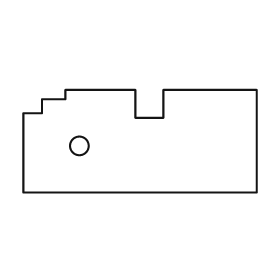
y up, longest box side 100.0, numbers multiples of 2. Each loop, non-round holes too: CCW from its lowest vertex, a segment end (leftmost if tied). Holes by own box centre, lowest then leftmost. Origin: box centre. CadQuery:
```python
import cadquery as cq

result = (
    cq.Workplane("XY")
    .moveTo(-50.0, -22.0)
    .lineTo(50.0, -22.0)
    .lineTo(50.0, 22.0)
    .lineTo(10.0, 22.0)
    .lineTo(10.0, 10.0)
    .lineTo(-2.0, 10.0)
    .lineTo(-2.0, 22.0)
    .lineTo(-32.0, 22.0)
    .lineTo(-32.0, 18.0)
    .lineTo(-42.0, 18.0)
    .lineTo(-42.0, 12.0)
    .lineTo(-50.0, 12.0)
    .close()
    .moveTo(-26.0, -2.0)
    .circle(4.0)
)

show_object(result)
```